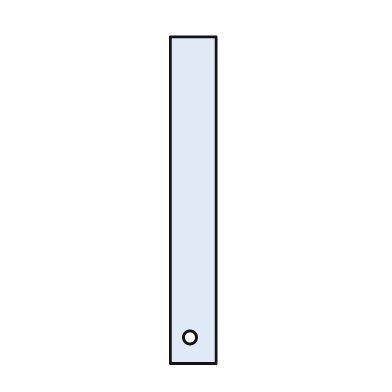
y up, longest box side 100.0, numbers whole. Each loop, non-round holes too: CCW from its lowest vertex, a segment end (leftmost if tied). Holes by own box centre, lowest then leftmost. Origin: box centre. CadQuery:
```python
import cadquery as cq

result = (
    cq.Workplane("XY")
    .moveTo(-7.0, -50.0)
    .lineTo(7.0, -50.0)
    .lineTo(7.0, 50.0)
    .lineTo(-7.0, 50.0)
    .close()
    .moveTo(-1.0, -42.0)
    .circle(2.0)
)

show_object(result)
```